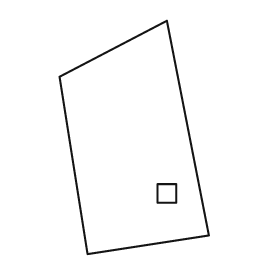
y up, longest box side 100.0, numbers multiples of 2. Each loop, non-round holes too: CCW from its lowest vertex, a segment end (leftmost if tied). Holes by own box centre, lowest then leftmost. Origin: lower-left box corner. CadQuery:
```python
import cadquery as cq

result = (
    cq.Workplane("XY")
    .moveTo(12.0, 0.0)
    .lineTo(64.0, 8.0)
    .lineTo(46.0, 100.0)
    .lineTo(0.0, 76.0)
    .close()
    .moveTo(42.0, 22.0)
    .lineTo(50.0, 22.0)
    .lineTo(50.0, 30.0)
    .lineTo(42.0, 30.0)
    .close()
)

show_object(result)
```